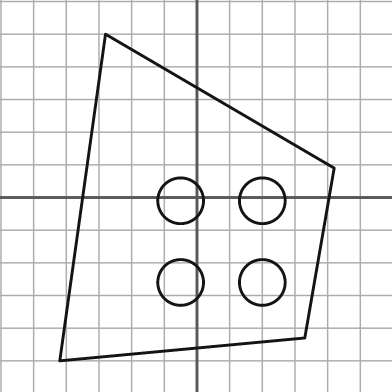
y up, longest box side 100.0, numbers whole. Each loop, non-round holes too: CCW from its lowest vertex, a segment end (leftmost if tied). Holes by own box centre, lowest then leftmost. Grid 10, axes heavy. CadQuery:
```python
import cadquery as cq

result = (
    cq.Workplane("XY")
    .moveTo(-42.0, -50.0)
    .lineTo(33.0, -43.0)
    .lineTo(42.0, 9.0)
    .lineTo(-28.0, 50.0)
    .close()
    .moveTo(-5.0, -26.0)
    .circle(7.0)
    .moveTo(20.0, -26.0)
    .circle(7.0)
    .moveTo(-5.0, -1.0)
    .circle(7.0)
    .moveTo(20.0, -1.0)
    .circle(7.0)
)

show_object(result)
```